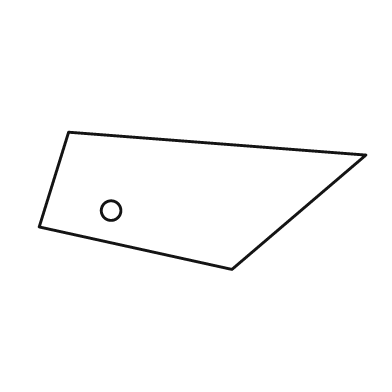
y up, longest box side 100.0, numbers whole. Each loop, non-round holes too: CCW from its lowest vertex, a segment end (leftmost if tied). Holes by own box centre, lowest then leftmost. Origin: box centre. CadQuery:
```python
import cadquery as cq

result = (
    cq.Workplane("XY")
    .moveTo(9.0, -21.0)
    .lineTo(50.0, 14.0)
    .lineTo(-41.0, 21.0)
    .lineTo(-50.0, -8.0)
    .close()
    .moveTo(-28.0, -3.0)
    .circle(3.0)
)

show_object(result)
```